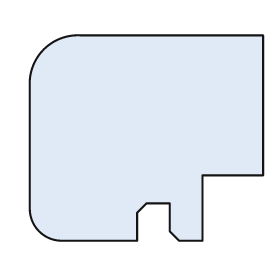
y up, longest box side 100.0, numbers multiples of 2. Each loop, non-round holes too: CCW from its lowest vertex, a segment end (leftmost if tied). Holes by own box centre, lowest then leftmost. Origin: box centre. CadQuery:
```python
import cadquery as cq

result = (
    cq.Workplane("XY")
    .moveTo(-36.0, -44.0)
    .lineTo(-4.0, -44.0)
    .lineTo(-4.0, -32.0)
    .lineTo(0.0, -28.0)
    .lineTo(10.0, -28.0)
    .lineTo(10.0, -40.0)
    .lineTo(14.0, -44.0)
    .lineTo(24.0, -44.0)
    .lineTo(24.0, -16.0)
    .lineTo(50.0, -16.0)
    .lineTo(50.0, 44.0)
    .lineTo(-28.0, 44.0)
    .threePointArc((-44.0, 38.0), (-50.0, 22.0))
    .lineTo(-50.0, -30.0)
    .threePointArc((-46.0, -40.0), (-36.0, -44.0))
    .close()
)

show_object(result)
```